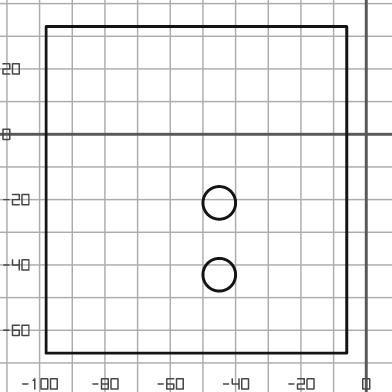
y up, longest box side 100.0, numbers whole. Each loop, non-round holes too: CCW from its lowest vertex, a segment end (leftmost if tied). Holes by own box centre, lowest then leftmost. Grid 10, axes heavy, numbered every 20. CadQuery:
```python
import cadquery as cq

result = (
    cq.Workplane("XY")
    .moveTo(-98.0, -67.0)
    .lineTo(-6.0, -67.0)
    .lineTo(-6.0, 33.0)
    .lineTo(-98.0, 33.0)
    .close()
    .moveTo(-45.0, -43.0)
    .circle(5.0)
    .moveTo(-45.0, -21.0)
    .circle(5.0)
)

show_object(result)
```